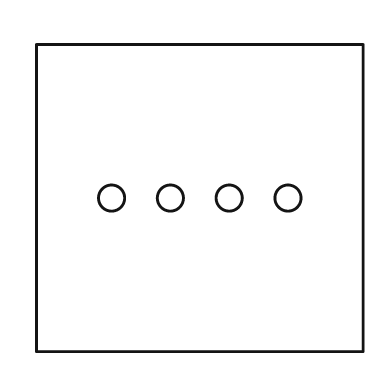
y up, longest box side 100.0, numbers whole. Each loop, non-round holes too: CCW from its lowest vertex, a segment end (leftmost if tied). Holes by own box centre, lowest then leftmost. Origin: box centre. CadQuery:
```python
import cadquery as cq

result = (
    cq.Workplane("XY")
    .moveTo(-50.0, -47.0)
    .lineTo(50.0, -47.0)
    .lineTo(50.0, 47.0)
    .lineTo(-50.0, 47.0)
    .close()
    .moveTo(-27.0, 0.0)
    .circle(4.0)
    .moveTo(-9.0, 0.0)
    .circle(4.0)
    .moveTo(9.0, 0.0)
    .circle(4.0)
    .moveTo(27.0, 0.0)
    .circle(4.0)
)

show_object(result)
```